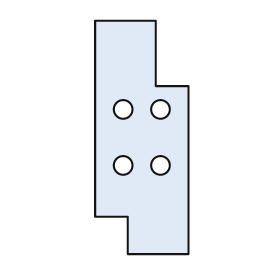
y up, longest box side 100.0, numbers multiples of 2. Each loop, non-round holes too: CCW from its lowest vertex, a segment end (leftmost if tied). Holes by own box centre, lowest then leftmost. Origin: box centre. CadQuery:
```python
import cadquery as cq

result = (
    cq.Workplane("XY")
    .moveTo(-6.0, -50.0)
    .lineTo(20.0, -50.0)
    .lineTo(20.0, 22.0)
    .lineTo(6.0, 22.0)
    .lineTo(6.0, 50.0)
    .lineTo(-20.0, 50.0)
    .lineTo(-20.0, -34.0)
    .lineTo(-6.0, -34.0)
    .close()
    .moveTo(-8.0, -12.0)
    .circle(4.0)
    .moveTo(8.0, -12.0)
    .circle(4.0)
    .moveTo(-8.0, 12.0)
    .circle(4.0)
    .moveTo(8.0, 12.0)
    .circle(4.0)
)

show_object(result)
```